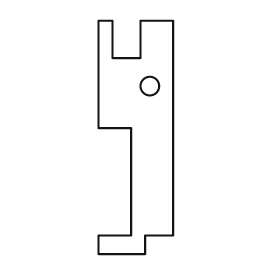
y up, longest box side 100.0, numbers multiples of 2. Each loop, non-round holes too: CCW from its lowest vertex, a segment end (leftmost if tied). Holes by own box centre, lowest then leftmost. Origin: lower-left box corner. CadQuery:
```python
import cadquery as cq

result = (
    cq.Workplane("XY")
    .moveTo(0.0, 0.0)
    .lineTo(20.0, 0.0)
    .lineTo(20.0, 8.0)
    .lineTo(32.0, 8.0)
    .lineTo(32.0, 100.0)
    .lineTo(18.0, 100.0)
    .lineTo(18.0, 84.0)
    .lineTo(6.0, 84.0)
    .lineTo(6.0, 100.0)
    .lineTo(0.0, 100.0)
    .lineTo(0.0, 54.0)
    .lineTo(14.0, 54.0)
    .lineTo(14.0, 8.0)
    .lineTo(0.0, 8.0)
    .close()
    .moveTo(22.0, 72.0)
    .circle(4.0)
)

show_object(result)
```